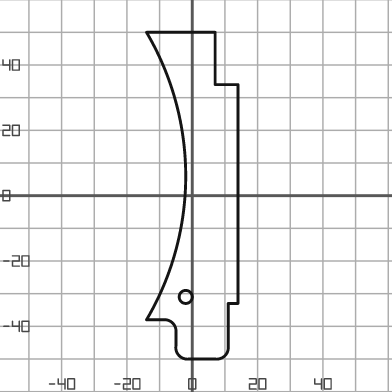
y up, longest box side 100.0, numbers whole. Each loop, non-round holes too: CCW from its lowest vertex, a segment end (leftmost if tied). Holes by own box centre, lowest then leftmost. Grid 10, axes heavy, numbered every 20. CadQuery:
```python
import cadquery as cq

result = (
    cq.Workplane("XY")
    .moveTo(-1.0, -50.0)
    .lineTo(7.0, -50.0)
    .threePointArc((10.0, -49.0), (11.0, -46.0))
    .lineTo(11.0, -33.0)
    .lineTo(14.0, -33.0)
    .lineTo(14.0, 34.0)
    .lineTo(7.0, 34.0)
    .lineTo(7.0, 50.0)
    .lineTo(-14.0, 50.0)
    .threePointArc((-2.0, 6.0), (-14.0, -38.0))
    .lineTo(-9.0, -38.0)
    .threePointArc((-6.0, -39.0), (-5.0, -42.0))
    .lineTo(-5.0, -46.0)
    .threePointArc((-4.0, -49.0), (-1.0, -50.0))
    .close()
    .moveTo(-2.0, -31.0)
    .circle(2.0)
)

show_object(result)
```